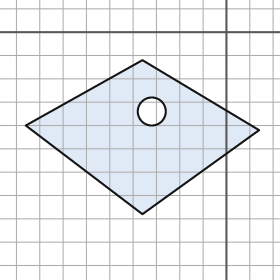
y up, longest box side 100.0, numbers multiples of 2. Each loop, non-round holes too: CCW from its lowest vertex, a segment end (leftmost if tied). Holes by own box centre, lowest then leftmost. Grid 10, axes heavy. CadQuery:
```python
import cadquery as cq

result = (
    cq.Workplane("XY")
    .moveTo(-36.0, -78.0)
    .lineTo(14.0, -42.0)
    .lineTo(-36.0, -12.0)
    .lineTo(-86.0, -40.0)
    .close()
    .moveTo(-32.0, -34.0)
    .circle(6.0)
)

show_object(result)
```